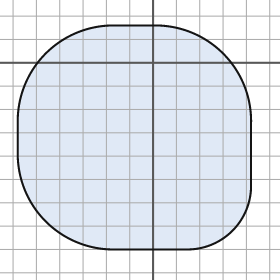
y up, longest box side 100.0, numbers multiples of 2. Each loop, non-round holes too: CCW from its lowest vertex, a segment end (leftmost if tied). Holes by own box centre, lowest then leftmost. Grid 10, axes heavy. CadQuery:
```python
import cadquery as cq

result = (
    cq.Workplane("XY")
    .moveTo(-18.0, -80.0)
    .lineTo(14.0, -80.0)
    .threePointArc((34.0, -72.0), (42.0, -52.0))
    .lineTo(42.0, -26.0)
    .threePointArc((30.0, 4.0), (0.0, 16.0))
    .lineTo(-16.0, 16.0)
    .threePointArc((-46.0, 4.0), (-58.0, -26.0))
    .lineTo(-58.0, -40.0)
    .threePointArc((-46.0, -68.0), (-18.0, -80.0))
    .close()
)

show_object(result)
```